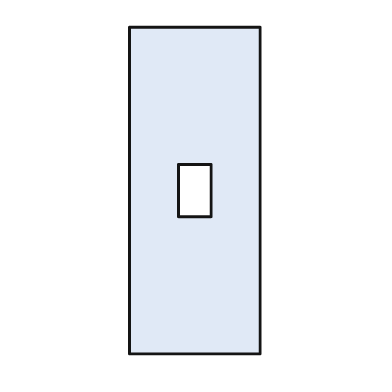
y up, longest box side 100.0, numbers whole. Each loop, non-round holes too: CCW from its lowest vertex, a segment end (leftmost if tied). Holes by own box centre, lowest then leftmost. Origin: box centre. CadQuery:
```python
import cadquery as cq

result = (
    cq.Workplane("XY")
    .moveTo(-20.0, -50.0)
    .lineTo(20.0, -50.0)
    .lineTo(20.0, 50.0)
    .lineTo(-20.0, 50.0)
    .close()
    .moveTo(-5.0, -8.0)
    .lineTo(5.0, -8.0)
    .lineTo(5.0, 8.0)
    .lineTo(-5.0, 8.0)
    .close()
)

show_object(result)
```